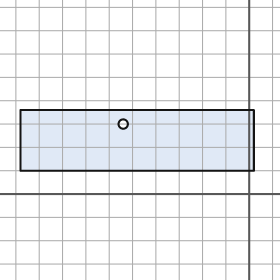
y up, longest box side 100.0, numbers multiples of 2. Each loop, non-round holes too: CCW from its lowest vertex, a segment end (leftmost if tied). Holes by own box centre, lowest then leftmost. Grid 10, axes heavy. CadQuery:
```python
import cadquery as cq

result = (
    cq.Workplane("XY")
    .moveTo(-98.0, 10.0)
    .lineTo(2.0, 10.0)
    .lineTo(2.0, 36.0)
    .lineTo(-98.0, 36.0)
    .close()
    .moveTo(-54.0, 30.0)
    .circle(2.0)
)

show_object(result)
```